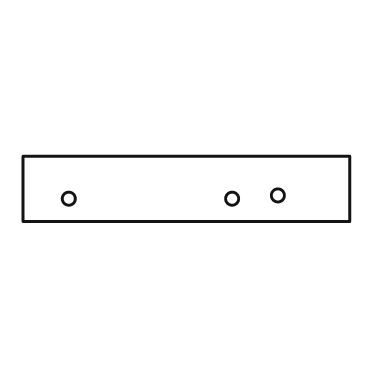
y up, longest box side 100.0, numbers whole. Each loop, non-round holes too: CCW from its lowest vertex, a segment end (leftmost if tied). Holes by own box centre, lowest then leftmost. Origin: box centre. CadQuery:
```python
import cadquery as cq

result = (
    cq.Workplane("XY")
    .moveTo(-50.0, -10.0)
    .lineTo(50.0, -10.0)
    .lineTo(50.0, 10.0)
    .lineTo(-50.0, 10.0)
    .close()
    .moveTo(-36.0, -3.0)
    .circle(2.0)
    .moveTo(14.0, -3.0)
    .circle(2.0)
    .moveTo(28.0, -2.0)
    .circle(2.0)
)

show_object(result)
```